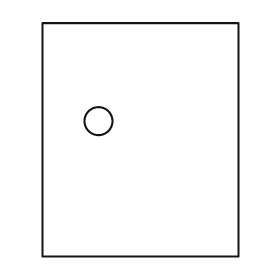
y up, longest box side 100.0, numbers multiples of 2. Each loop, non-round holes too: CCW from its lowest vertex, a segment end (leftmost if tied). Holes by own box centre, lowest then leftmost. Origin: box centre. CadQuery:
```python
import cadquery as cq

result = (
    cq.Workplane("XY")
    .moveTo(-42.0, -50.0)
    .lineTo(42.0, -50.0)
    .lineTo(42.0, 50.0)
    .lineTo(-42.0, 50.0)
    .close()
    .moveTo(-18.0, 8.0)
    .circle(6.0)
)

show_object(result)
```